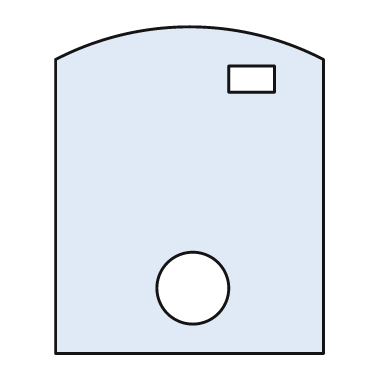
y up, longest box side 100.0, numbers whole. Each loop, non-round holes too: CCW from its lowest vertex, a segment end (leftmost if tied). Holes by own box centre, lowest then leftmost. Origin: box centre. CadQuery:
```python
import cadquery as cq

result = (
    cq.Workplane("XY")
    .moveTo(-41.0, -50.0)
    .lineTo(41.0, -50.0)
    .lineTo(41.0, 40.0)
    .threePointArc((0.0, 50.0), (-41.0, 40.0))
    .close()
    .moveTo(1.0, -30.0)
    .circle(11.0)
    .moveTo(12.0, 30.0)
    .lineTo(26.0, 30.0)
    .lineTo(26.0, 38.0)
    .lineTo(12.0, 38.0)
    .close()
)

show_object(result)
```